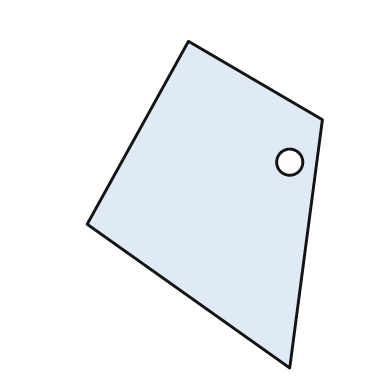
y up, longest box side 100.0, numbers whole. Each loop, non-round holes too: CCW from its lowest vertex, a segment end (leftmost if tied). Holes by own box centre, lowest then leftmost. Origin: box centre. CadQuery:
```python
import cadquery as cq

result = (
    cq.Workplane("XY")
    .moveTo(26.0, -50.0)
    .lineTo(36.0, 26.0)
    .lineTo(-5.0, 50.0)
    .lineTo(-36.0, -6.0)
    .close()
    .moveTo(26.0, 13.0)
    .circle(4.0)
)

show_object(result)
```